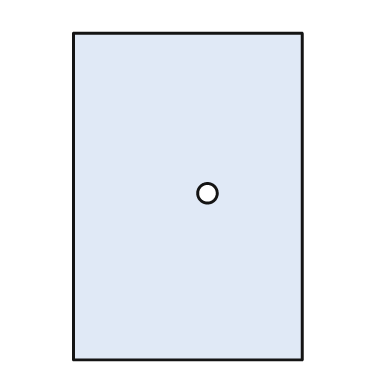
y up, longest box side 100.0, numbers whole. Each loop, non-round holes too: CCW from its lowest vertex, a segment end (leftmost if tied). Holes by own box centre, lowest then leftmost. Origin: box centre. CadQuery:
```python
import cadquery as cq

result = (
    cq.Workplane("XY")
    .moveTo(-35.0, -50.0)
    .lineTo(35.0, -50.0)
    .lineTo(35.0, 50.0)
    .lineTo(-35.0, 50.0)
    .close()
    .moveTo(6.0, 1.0)
    .circle(3.0)
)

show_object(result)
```